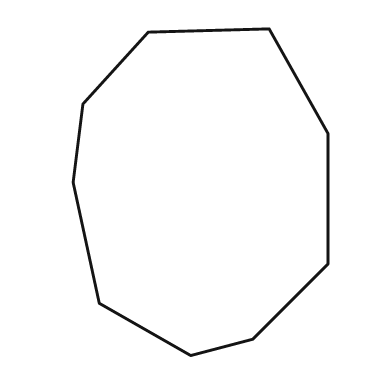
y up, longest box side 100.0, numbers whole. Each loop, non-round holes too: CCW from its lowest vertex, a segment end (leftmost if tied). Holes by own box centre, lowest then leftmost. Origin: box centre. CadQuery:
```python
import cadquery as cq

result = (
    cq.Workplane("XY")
    .moveTo(-3.0, -50.0)
    .lineTo(16.0, -45.0)
    .lineTo(39.0, -22.0)
    .lineTo(39.0, 18.0)
    .lineTo(21.0, 50.0)
    .lineTo(-16.0, 49.0)
    .lineTo(-36.0, 27.0)
    .lineTo(-39.0, 3.0)
    .lineTo(-31.0, -34.0)
    .close()
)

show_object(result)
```